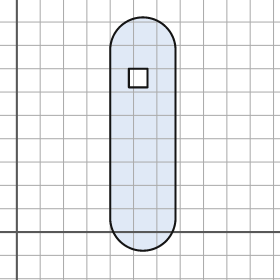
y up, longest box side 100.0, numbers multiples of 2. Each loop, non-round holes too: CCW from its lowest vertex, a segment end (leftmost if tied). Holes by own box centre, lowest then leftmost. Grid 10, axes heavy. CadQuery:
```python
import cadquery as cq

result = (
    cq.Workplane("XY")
    .moveTo(40.0, 6.0)
    .threePointArc((54.0, -8.0), (68.0, 6.0))
    .lineTo(68.0, 78.0)
    .threePointArc((54.0, 92.0), (40.0, 78.0))
    .close()
    .moveTo(48.0, 62.0)
    .lineTo(56.0, 62.0)
    .lineTo(56.0, 70.0)
    .lineTo(48.0, 70.0)
    .close()
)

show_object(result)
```